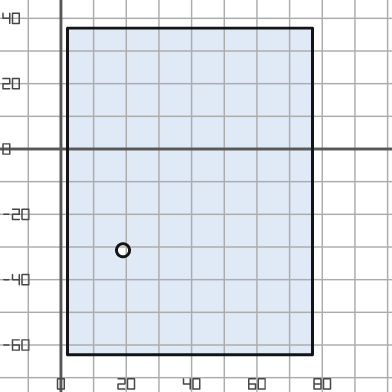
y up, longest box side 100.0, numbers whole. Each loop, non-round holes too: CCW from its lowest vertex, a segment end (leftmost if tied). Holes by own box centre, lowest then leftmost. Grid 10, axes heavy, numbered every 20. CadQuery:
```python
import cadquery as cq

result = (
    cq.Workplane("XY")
    .moveTo(2.0, -63.0)
    .lineTo(77.0, -63.0)
    .lineTo(77.0, 37.0)
    .lineTo(2.0, 37.0)
    .close()
    .moveTo(19.0, -31.0)
    .circle(2.0)
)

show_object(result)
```